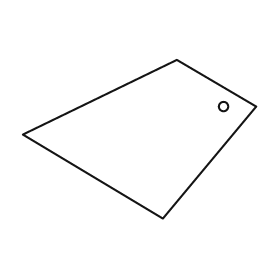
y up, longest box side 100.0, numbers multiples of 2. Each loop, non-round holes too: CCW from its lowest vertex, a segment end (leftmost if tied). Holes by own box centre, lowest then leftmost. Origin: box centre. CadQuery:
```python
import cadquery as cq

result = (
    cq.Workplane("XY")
    .moveTo(10.0, -34.0)
    .lineTo(50.0, 14.0)
    .lineTo(16.0, 34.0)
    .lineTo(-50.0, 2.0)
    .close()
    .moveTo(36.0, 14.0)
    .circle(2.0)
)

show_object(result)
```